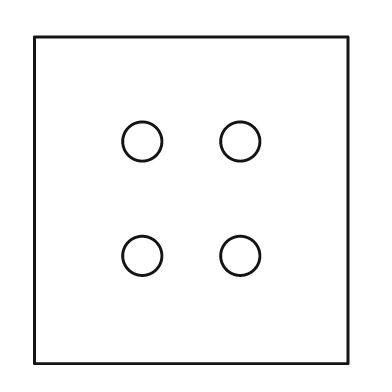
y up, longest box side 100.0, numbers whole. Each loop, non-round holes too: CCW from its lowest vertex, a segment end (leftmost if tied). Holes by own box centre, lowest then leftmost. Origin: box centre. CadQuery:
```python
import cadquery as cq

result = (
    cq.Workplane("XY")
    .moveTo(-48.0, -50.0)
    .lineTo(48.0, -50.0)
    .lineTo(48.0, 50.0)
    .lineTo(-48.0, 50.0)
    .close()
    .moveTo(-15.0, -17.0)
    .circle(6.0)
    .moveTo(15.0, -17.0)
    .circle(6.0)
    .moveTo(-15.0, 18.0)
    .circle(6.0)
    .moveTo(15.0, 18.0)
    .circle(6.0)
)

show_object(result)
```